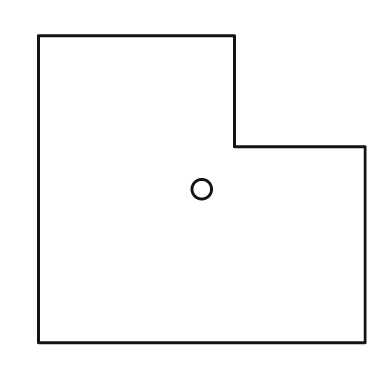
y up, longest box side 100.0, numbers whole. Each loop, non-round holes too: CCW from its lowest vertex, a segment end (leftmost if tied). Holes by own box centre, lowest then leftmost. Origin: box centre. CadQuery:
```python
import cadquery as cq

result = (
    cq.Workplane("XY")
    .moveTo(-50.0, -47.0)
    .lineTo(50.0, -47.0)
    .lineTo(50.0, 13.0)
    .lineTo(10.0, 13.0)
    .lineTo(10.0, 47.0)
    .lineTo(-50.0, 47.0)
    .close()
    .moveTo(0.0, 0.0)
    .circle(3.0)
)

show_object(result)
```